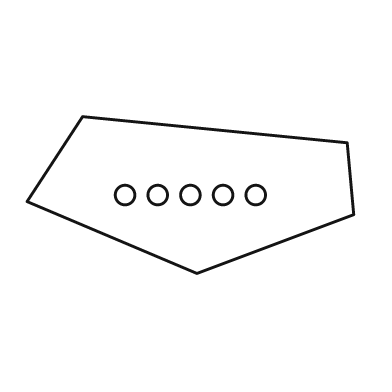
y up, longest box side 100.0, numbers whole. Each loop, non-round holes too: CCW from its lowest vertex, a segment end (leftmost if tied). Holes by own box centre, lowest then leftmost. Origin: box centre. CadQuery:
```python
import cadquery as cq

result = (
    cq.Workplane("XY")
    .moveTo(2.0, -24.0)
    .lineTo(50.0, -6.0)
    .lineTo(48.0, 16.0)
    .lineTo(-33.0, 24.0)
    .lineTo(-50.0, -2.0)
    .close()
    .moveTo(-20.0, 0.0)
    .circle(3.0)
    .moveTo(-10.0, 0.0)
    .circle(3.0)
    .moveTo(0.0, 0.0)
    .circle(3.0)
    .moveTo(10.0, 0.0)
    .circle(3.0)
    .moveTo(20.0, 0.0)
    .circle(3.0)
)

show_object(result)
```